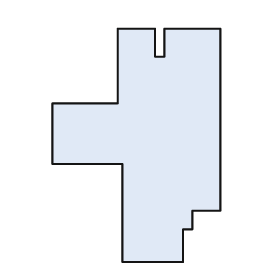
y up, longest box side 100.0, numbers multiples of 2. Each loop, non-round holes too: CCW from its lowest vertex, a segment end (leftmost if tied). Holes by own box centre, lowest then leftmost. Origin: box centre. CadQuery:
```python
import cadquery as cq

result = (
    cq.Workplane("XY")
    .moveTo(-6.0, -50.0)
    .lineTo(20.0, -50.0)
    .lineTo(20.0, -36.0)
    .lineTo(24.0, -36.0)
    .lineTo(24.0, -28.0)
    .lineTo(36.0, -28.0)
    .lineTo(36.0, 50.0)
    .lineTo(12.0, 50.0)
    .lineTo(12.0, 38.0)
    .lineTo(8.0, 38.0)
    .lineTo(8.0, 50.0)
    .lineTo(-8.0, 50.0)
    .lineTo(-8.0, 18.0)
    .lineTo(-36.0, 18.0)
    .lineTo(-36.0, -8.0)
    .lineTo(-6.0, -8.0)
    .close()
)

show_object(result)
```